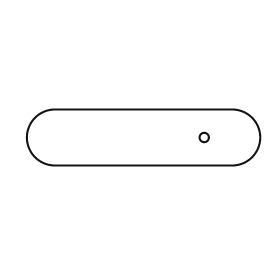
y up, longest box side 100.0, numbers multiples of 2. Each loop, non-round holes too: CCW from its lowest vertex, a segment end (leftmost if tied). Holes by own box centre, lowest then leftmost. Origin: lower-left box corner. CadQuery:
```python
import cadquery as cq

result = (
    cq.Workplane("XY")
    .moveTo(12.0, 0.0)
    .lineTo(88.0, 0.0)
    .threePointArc((100.0, 12.0), (88.0, 24.0))
    .lineTo(12.0, 24.0)
    .threePointArc((0.0, 12.0), (12.0, 0.0))
    .close()
    .moveTo(76.0, 12.0)
    .circle(2.0)
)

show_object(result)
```